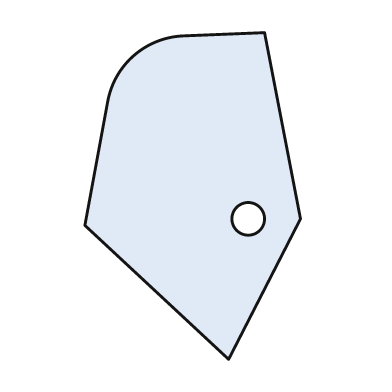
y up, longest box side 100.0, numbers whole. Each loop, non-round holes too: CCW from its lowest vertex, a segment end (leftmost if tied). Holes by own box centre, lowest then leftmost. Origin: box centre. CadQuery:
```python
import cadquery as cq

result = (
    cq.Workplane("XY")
    .moveTo(11.0, -50.0)
    .lineTo(33.0, -7.0)
    .lineTo(22.0, 50.0)
    .lineTo(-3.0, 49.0)
    .threePointArc((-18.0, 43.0), (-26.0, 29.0))
    .lineTo(-33.0, -9.0)
    .close()
    .moveTo(17.0, -7.0)
    .circle(5.0)
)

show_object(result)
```